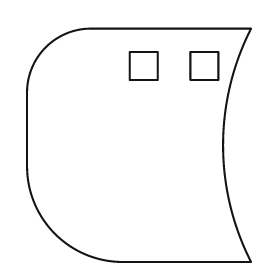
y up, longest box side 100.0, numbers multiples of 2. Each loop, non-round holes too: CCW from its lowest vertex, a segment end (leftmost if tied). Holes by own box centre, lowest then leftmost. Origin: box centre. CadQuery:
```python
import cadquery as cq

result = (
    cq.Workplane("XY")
    .moveTo(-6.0, -50.0)
    .lineTo(48.0, -50.0)
    .threePointArc((36.0, 0.0), (48.0, 50.0))
    .lineTo(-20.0, 50.0)
    .threePointArc((-40.0, 42.0), (-48.0, 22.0))
    .lineTo(-48.0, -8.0)
    .threePointArc((-36.0, -38.0), (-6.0, -50.0))
    .close()
    .moveTo(-4.0, 28.0)
    .lineTo(8.0, 28.0)
    .lineTo(8.0, 40.0)
    .lineTo(-4.0, 40.0)
    .close()
    .moveTo(22.0, 28.0)
    .lineTo(34.0, 28.0)
    .lineTo(34.0, 40.0)
    .lineTo(22.0, 40.0)
    .close()
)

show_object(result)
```